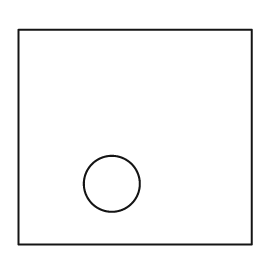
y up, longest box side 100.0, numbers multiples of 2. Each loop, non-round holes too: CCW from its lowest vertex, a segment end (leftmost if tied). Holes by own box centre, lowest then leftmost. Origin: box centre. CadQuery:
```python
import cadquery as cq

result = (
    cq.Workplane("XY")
    .moveTo(-50.0, -46.0)
    .lineTo(50.0, -46.0)
    .lineTo(50.0, 46.0)
    .lineTo(-50.0, 46.0)
    .close()
    .moveTo(-10.0, -20.0)
    .circle(12.0)
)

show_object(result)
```